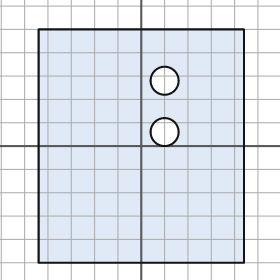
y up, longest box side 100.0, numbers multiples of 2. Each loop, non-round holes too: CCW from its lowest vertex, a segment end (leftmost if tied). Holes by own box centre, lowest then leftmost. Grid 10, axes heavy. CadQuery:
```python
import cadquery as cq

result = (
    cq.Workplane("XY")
    .moveTo(-44.0, -50.0)
    .lineTo(44.0, -50.0)
    .lineTo(44.0, 50.0)
    .lineTo(-44.0, 50.0)
    .close()
    .moveTo(10.0, 6.0)
    .circle(6.0)
    .moveTo(10.0, 28.0)
    .circle(6.0)
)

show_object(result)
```